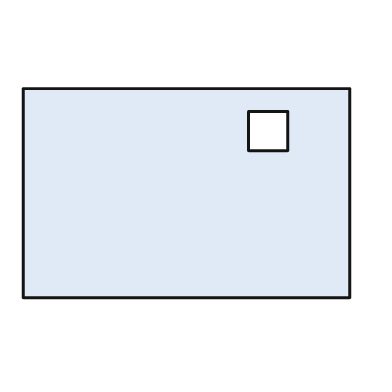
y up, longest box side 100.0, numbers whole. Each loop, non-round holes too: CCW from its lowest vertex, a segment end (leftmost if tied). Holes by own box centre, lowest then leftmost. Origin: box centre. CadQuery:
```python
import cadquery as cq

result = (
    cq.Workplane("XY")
    .moveTo(-50.0, -32.0)
    .lineTo(50.0, -32.0)
    .lineTo(50.0, 32.0)
    .lineTo(-50.0, 32.0)
    .close()
    .moveTo(19.0, 13.0)
    .lineTo(31.0, 13.0)
    .lineTo(31.0, 25.0)
    .lineTo(19.0, 25.0)
    .close()
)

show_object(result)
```